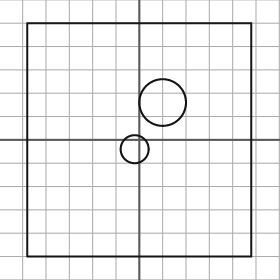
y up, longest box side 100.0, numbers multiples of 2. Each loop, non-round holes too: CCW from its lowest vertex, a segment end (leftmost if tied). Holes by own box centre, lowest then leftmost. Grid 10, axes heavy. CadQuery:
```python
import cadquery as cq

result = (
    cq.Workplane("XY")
    .moveTo(-48.0, -50.0)
    .lineTo(48.0, -50.0)
    .lineTo(48.0, 50.0)
    .lineTo(-48.0, 50.0)
    .close()
    .moveTo(-2.0, -4.0)
    .circle(6.0)
    .moveTo(10.0, 16.0)
    .circle(10.0)
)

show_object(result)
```